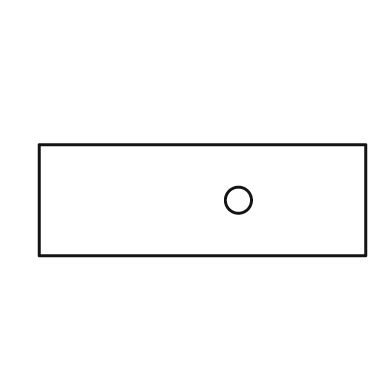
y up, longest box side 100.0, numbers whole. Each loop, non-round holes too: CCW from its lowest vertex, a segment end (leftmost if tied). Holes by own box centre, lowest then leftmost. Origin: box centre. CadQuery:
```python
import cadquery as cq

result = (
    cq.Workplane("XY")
    .moveTo(-50.0, -17.0)
    .lineTo(50.0, -17.0)
    .lineTo(50.0, 17.0)
    .lineTo(-50.0, 17.0)
    .close()
    .moveTo(11.0, 0.0)
    .circle(4.0)
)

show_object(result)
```